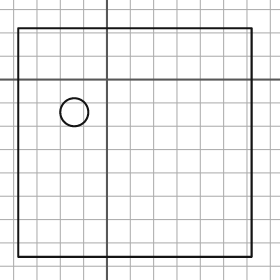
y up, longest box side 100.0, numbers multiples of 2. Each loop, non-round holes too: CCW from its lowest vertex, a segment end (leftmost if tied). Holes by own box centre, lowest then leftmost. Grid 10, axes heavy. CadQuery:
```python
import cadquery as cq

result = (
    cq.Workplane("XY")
    .moveTo(-38.0, -76.0)
    .lineTo(62.0, -76.0)
    .lineTo(62.0, 22.0)
    .lineTo(-38.0, 22.0)
    .close()
    .moveTo(-14.0, -14.0)
    .circle(6.0)
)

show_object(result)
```